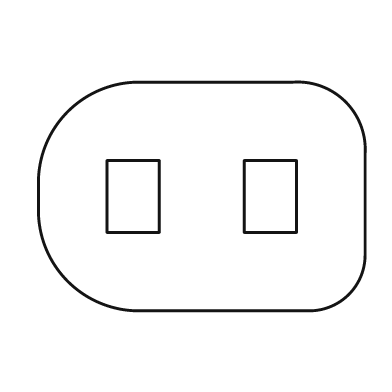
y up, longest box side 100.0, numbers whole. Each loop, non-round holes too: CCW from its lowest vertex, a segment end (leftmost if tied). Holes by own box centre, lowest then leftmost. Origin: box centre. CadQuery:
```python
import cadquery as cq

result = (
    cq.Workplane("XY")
    .moveTo(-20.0, -35.0)
    .lineTo(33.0, -35.0)
    .threePointArc((45.0, -30.0), (50.0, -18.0))
    .lineTo(50.0, 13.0)
    .threePointArc((44.0, 29.0), (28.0, 35.0))
    .lineTo(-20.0, 35.0)
    .threePointArc((-41.0, 26.0), (-50.0, 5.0))
    .lineTo(-50.0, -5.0)
    .threePointArc((-41.0, -26.0), (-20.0, -35.0))
    .close()
    .moveTo(-29.0, -11.0)
    .lineTo(-13.0, -11.0)
    .lineTo(-13.0, 11.0)
    .lineTo(-29.0, 11.0)
    .close()
    .moveTo(13.0, -11.0)
    .lineTo(29.0, -11.0)
    .lineTo(29.0, 11.0)
    .lineTo(13.0, 11.0)
    .close()
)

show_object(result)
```